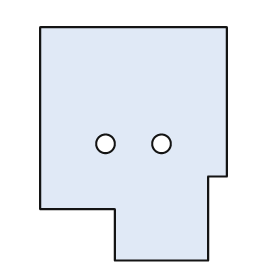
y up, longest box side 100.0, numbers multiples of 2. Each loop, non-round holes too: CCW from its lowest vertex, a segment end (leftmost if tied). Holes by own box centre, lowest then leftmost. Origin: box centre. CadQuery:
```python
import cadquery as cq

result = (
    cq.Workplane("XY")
    .moveTo(-8.0, -50.0)
    .lineTo(32.0, -50.0)
    .lineTo(32.0, -14.0)
    .lineTo(40.0, -14.0)
    .lineTo(40.0, 50.0)
    .lineTo(-40.0, 50.0)
    .lineTo(-40.0, -28.0)
    .lineTo(-8.0, -28.0)
    .close()
    .moveTo(-12.0, 0.0)
    .circle(4.0)
    .moveTo(12.0, 0.0)
    .circle(4.0)
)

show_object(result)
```